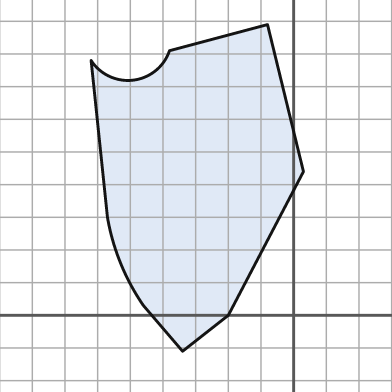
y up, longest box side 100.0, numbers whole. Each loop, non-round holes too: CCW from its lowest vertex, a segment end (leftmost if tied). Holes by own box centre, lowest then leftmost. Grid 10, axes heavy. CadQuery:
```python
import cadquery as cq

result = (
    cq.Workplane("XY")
    .moveTo(-34.0, -11.0)
    .lineTo(-20.0, 0.0)
    .lineTo(3.0, 44.0)
    .lineTo(-8.0, 89.0)
    .lineTo(-38.0, 81.0)
    .threePointArc((-49.0, 72.0), (-62.0, 78.0))
    .lineTo(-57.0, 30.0)
    .threePointArc((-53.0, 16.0), (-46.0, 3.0))
    .close()
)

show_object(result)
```